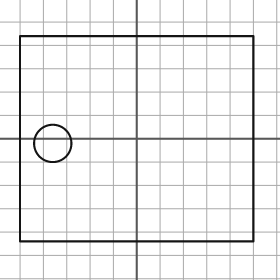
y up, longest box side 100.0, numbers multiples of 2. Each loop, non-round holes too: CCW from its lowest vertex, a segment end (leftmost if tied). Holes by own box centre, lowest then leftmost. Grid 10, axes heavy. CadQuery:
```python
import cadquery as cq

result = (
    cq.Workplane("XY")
    .moveTo(-50.0, -44.0)
    .lineTo(50.0, -44.0)
    .lineTo(50.0, 44.0)
    .lineTo(-50.0, 44.0)
    .close()
    .moveTo(-36.0, -2.0)
    .circle(8.0)
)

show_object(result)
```